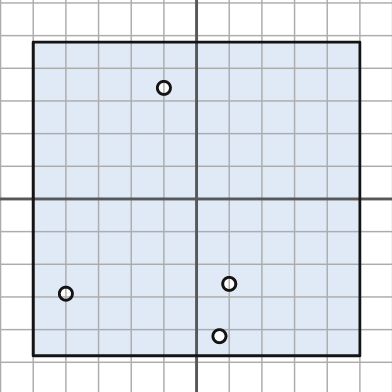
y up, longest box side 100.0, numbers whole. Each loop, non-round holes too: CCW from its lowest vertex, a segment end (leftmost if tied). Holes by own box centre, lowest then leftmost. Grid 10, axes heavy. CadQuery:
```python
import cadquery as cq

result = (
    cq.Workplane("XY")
    .moveTo(-50.0, -48.0)
    .lineTo(50.0, -48.0)
    .lineTo(50.0, 48.0)
    .lineTo(-50.0, 48.0)
    .close()
    .moveTo(7.0, -42.0)
    .circle(2.0)
    .moveTo(-40.0, -29.0)
    .circle(2.0)
    .moveTo(10.0, -26.0)
    .circle(2.0)
    .moveTo(-10.0, 34.0)
    .circle(2.0)
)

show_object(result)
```